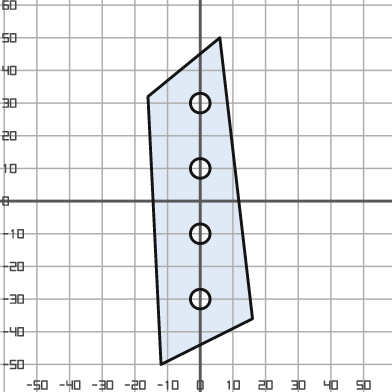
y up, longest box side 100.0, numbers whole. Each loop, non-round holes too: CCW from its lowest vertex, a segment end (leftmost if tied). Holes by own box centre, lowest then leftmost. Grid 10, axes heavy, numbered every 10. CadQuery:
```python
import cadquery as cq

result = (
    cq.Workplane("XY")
    .moveTo(-12.0, -50.0)
    .lineTo(16.0, -36.0)
    .lineTo(6.0, 50.0)
    .lineTo(-16.0, 32.0)
    .close()
    .moveTo(0.0, -30.0)
    .circle(3.0)
    .moveTo(0.0, -10.0)
    .circle(3.0)
    .moveTo(0.0, 10.0)
    .circle(3.0)
    .moveTo(0.0, 30.0)
    .circle(3.0)
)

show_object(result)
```